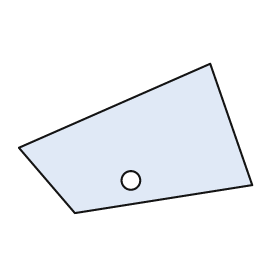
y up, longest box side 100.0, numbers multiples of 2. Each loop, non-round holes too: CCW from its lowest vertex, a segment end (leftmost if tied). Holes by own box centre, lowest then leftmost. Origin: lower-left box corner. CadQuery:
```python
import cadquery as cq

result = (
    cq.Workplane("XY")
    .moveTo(24.0, 0.0)
    .lineTo(100.0, 12.0)
    .lineTo(82.0, 64.0)
    .lineTo(0.0, 28.0)
    .close()
    .moveTo(48.0, 14.0)
    .circle(4.0)
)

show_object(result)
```